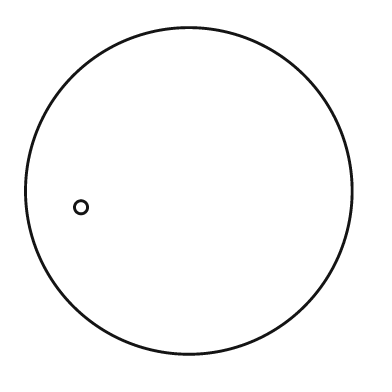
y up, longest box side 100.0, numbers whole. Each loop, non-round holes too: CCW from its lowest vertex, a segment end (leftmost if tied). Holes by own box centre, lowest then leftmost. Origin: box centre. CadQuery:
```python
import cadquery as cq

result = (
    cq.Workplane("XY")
    .moveTo(0.0, 0.0)
    .circle(50.0)
    .moveTo(-33.0, -5.0)
    .circle(2.0)
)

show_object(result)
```